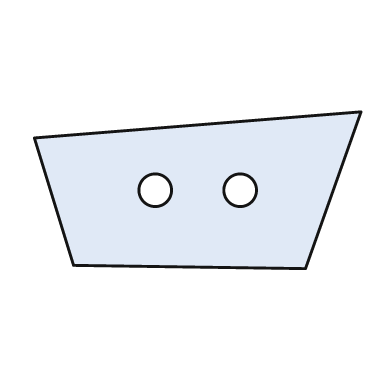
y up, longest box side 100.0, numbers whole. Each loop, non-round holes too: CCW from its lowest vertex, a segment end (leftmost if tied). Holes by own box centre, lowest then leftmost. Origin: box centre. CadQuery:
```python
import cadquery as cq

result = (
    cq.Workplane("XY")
    .moveTo(33.0, -24.0)
    .lineTo(50.0, 24.0)
    .lineTo(-50.0, 16.0)
    .lineTo(-38.0, -23.0)
    .close()
    .moveTo(-13.0, 0.0)
    .circle(5.0)
    .moveTo(13.0, 0.0)
    .circle(5.0)
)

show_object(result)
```